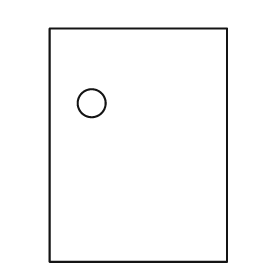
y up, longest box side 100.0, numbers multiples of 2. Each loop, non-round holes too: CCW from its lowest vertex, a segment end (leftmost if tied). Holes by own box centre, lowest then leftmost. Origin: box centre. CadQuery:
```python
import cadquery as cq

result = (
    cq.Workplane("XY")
    .moveTo(-38.0, -50.0)
    .lineTo(38.0, -50.0)
    .lineTo(38.0, 50.0)
    .lineTo(-38.0, 50.0)
    .close()
    .moveTo(-20.0, 18.0)
    .circle(6.0)
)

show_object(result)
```